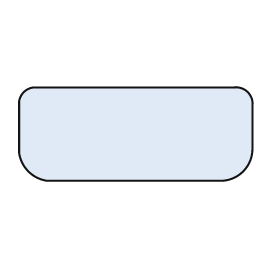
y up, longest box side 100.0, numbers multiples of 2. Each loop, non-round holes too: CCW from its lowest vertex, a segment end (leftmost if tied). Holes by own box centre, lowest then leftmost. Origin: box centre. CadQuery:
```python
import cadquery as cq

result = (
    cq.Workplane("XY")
    .moveTo(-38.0, -20.0)
    .lineTo(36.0, -20.0)
    .threePointArc((46.0, -16.0), (50.0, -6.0))
    .lineTo(50.0, 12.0)
    .threePointArc((48.0, 18.0), (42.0, 20.0))
    .lineTo(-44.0, 20.0)
    .threePointArc((-48.0, 18.0), (-50.0, 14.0))
    .lineTo(-50.0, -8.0)
    .threePointArc((-46.0, -16.0), (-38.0, -20.0))
    .close()
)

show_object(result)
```